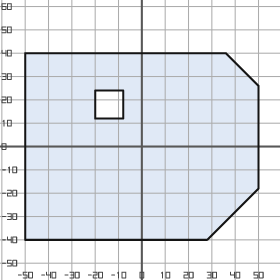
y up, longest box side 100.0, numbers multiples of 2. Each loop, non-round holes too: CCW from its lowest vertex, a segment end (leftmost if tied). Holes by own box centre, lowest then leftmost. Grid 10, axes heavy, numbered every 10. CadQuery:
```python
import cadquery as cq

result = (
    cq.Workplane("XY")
    .moveTo(-50.0, -40.0)
    .lineTo(28.0, -40.0)
    .lineTo(50.0, -18.0)
    .lineTo(50.0, 26.0)
    .lineTo(36.0, 40.0)
    .lineTo(-50.0, 40.0)
    .close()
    .moveTo(-20.0, 12.0)
    .lineTo(-8.0, 12.0)
    .lineTo(-8.0, 24.0)
    .lineTo(-20.0, 24.0)
    .close()
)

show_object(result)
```